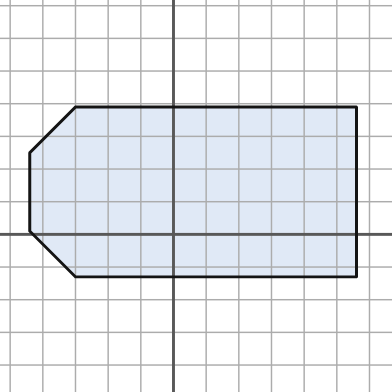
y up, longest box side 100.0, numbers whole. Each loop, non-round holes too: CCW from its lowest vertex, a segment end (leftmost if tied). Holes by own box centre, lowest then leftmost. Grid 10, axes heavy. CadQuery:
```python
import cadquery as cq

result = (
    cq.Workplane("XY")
    .moveTo(-30.0, -13.0)
    .lineTo(56.0, -13.0)
    .lineTo(56.0, 39.0)
    .lineTo(-30.0, 39.0)
    .lineTo(-44.0, 25.0)
    .lineTo(-44.0, 1.0)
    .close()
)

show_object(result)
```